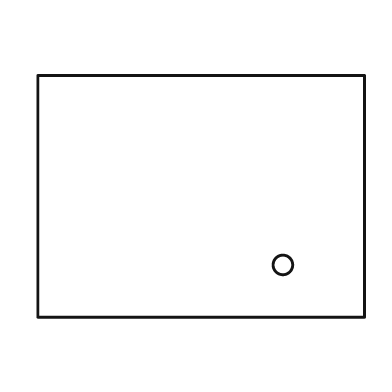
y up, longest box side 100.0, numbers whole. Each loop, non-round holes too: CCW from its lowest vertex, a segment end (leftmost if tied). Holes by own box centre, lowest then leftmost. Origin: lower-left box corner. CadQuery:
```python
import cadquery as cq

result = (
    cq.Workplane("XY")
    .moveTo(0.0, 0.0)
    .lineTo(100.0, 0.0)
    .lineTo(100.0, 74.0)
    .lineTo(0.0, 74.0)
    .close()
    .moveTo(75.0, 16.0)
    .circle(3.0)
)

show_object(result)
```